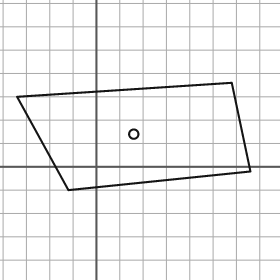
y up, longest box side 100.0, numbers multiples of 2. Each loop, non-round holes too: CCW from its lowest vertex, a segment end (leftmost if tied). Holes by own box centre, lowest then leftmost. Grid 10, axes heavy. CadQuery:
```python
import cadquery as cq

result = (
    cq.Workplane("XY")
    .moveTo(-12.0, -10.0)
    .lineTo(66.0, -2.0)
    .lineTo(58.0, 36.0)
    .lineTo(-34.0, 30.0)
    .close()
    .moveTo(16.0, 14.0)
    .circle(2.0)
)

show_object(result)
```